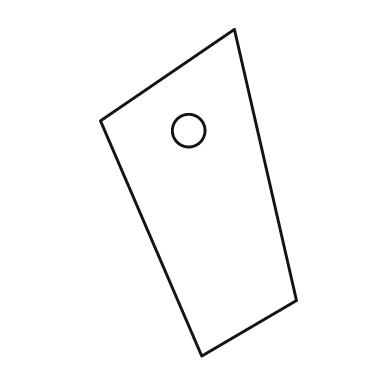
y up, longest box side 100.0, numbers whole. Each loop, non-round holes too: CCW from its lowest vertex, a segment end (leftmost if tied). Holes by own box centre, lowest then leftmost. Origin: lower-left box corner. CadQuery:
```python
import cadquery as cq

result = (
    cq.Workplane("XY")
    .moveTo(31.0, 0.0)
    .lineTo(60.0, 17.0)
    .lineTo(41.0, 100.0)
    .lineTo(0.0, 72.0)
    .close()
    .moveTo(27.0, 69.0)
    .circle(5.0)
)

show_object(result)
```